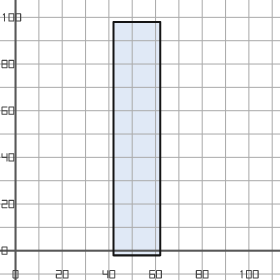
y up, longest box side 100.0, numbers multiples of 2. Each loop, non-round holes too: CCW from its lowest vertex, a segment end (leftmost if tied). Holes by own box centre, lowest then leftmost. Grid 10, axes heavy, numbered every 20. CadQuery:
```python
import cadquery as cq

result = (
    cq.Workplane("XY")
    .moveTo(42.0, -2.0)
    .lineTo(62.0, -2.0)
    .lineTo(62.0, 98.0)
    .lineTo(42.0, 98.0)
    .close()
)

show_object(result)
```